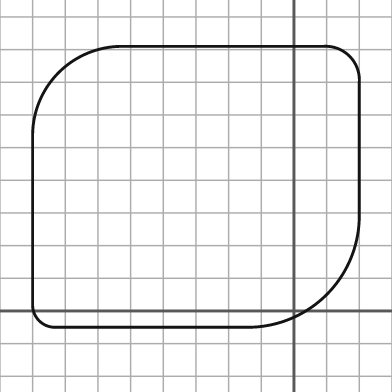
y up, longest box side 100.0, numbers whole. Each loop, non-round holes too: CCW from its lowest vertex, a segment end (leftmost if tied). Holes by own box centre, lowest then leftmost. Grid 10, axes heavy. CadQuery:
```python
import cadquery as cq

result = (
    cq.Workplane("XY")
    .moveTo(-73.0, -5.0)
    .lineTo(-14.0, -5.0)
    .threePointArc((10.0, 5.0), (20.0, 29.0))
    .lineTo(20.0, 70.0)
    .threePointArc((17.0, 78.0), (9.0, 81.0))
    .lineTo(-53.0, 81.0)
    .threePointArc((-72.0, 73.0), (-80.0, 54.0))
    .lineTo(-80.0, 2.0)
    .threePointArc((-78.0, -3.0), (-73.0, -5.0))
    .close()
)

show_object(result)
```